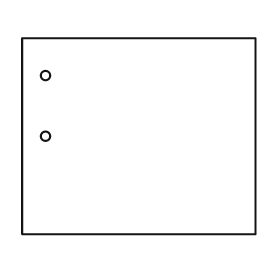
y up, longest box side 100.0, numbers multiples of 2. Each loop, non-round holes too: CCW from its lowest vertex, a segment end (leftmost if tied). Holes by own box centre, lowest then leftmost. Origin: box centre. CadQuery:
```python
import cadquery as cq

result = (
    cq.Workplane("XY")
    .moveTo(-50.0, -42.0)
    .lineTo(50.0, -42.0)
    .lineTo(50.0, 42.0)
    .lineTo(-50.0, 42.0)
    .close()
    .moveTo(-40.0, 0.0)
    .circle(2.0)
    .moveTo(-40.0, 26.0)
    .circle(2.0)
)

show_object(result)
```